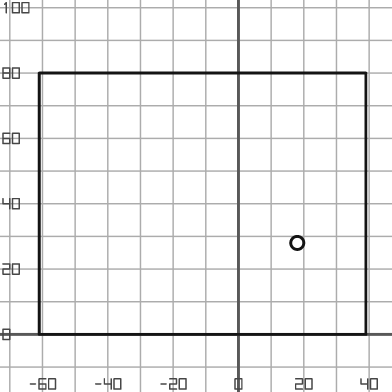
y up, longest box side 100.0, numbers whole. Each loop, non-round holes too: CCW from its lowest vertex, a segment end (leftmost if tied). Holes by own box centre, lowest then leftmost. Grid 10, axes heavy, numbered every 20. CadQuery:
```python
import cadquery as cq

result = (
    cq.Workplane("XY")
    .moveTo(-61.0, 0.0)
    .lineTo(39.0, 0.0)
    .lineTo(39.0, 80.0)
    .lineTo(-61.0, 80.0)
    .close()
    .moveTo(18.0, 28.0)
    .circle(2.0)
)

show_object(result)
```